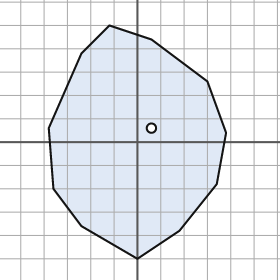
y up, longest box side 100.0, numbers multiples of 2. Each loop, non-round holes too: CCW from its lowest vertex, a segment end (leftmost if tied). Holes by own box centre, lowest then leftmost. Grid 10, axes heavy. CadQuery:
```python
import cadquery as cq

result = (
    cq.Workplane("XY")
    .moveTo(0.0, -50.0)
    .lineTo(18.0, -38.0)
    .lineTo(34.0, -18.0)
    .lineTo(38.0, 4.0)
    .lineTo(30.0, 26.0)
    .lineTo(6.0, 44.0)
    .lineTo(-12.0, 50.0)
    .lineTo(-24.0, 38.0)
    .lineTo(-38.0, 6.0)
    .lineTo(-36.0, -20.0)
    .lineTo(-24.0, -36.0)
    .close()
    .moveTo(6.0, 6.0)
    .circle(2.0)
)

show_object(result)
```